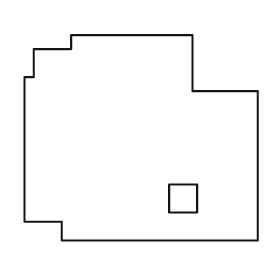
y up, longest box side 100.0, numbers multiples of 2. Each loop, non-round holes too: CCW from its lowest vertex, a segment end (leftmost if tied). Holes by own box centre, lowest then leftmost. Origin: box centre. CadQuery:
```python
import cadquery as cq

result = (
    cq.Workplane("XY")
    .moveTo(-34.0, -44.0)
    .lineTo(50.0, -44.0)
    .lineTo(50.0, 20.0)
    .lineTo(22.0, 20.0)
    .lineTo(22.0, 44.0)
    .lineTo(-30.0, 44.0)
    .lineTo(-30.0, 38.0)
    .lineTo(-46.0, 38.0)
    .lineTo(-46.0, 26.0)
    .lineTo(-50.0, 26.0)
    .lineTo(-50.0, -36.0)
    .lineTo(-34.0, -36.0)
    .close()
    .moveTo(12.0, -32.0)
    .lineTo(24.0, -32.0)
    .lineTo(24.0, -20.0)
    .lineTo(12.0, -20.0)
    .close()
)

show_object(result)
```